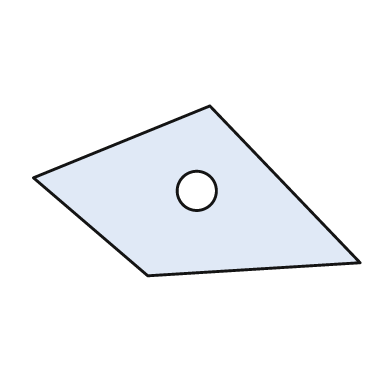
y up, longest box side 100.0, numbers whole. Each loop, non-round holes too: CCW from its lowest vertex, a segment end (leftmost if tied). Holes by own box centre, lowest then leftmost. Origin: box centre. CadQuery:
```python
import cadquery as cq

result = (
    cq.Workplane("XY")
    .moveTo(-15.0, -26.0)
    .lineTo(50.0, -22.0)
    .lineTo(4.0, 26.0)
    .lineTo(-50.0, 4.0)
    .close()
    .moveTo(0.0, 0.0)
    .circle(6.0)
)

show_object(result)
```